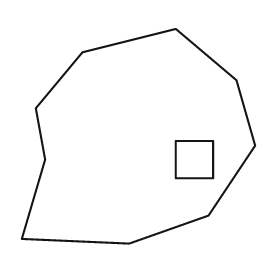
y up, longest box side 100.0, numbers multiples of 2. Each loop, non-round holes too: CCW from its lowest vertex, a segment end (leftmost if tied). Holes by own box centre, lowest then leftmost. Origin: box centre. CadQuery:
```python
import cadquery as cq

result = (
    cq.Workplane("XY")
    .moveTo(-4.0, -46.0)
    .lineTo(30.0, -34.0)
    .lineTo(50.0, -4.0)
    .lineTo(42.0, 24.0)
    .lineTo(16.0, 46.0)
    .lineTo(-24.0, 36.0)
    .lineTo(-44.0, 12.0)
    .lineTo(-40.0, -10.0)
    .lineTo(-50.0, -44.0)
    .close()
    .moveTo(16.0, -18.0)
    .lineTo(32.0, -18.0)
    .lineTo(32.0, -2.0)
    .lineTo(16.0, -2.0)
    .close()
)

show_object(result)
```